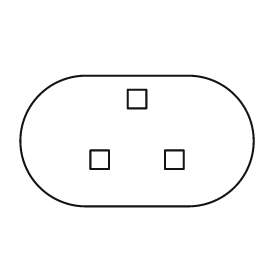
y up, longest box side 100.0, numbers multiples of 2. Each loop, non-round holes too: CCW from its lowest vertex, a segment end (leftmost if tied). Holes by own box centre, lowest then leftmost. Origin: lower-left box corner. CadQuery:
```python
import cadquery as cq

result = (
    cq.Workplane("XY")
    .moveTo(28.0, 0.0)
    .lineTo(72.0, 0.0)
    .threePointArc((100.0, 28.0), (72.0, 56.0))
    .lineTo(28.0, 56.0)
    .threePointArc((0.0, 28.0), (28.0, 0.0))
    .close()
    .moveTo(30.0, 16.0)
    .lineTo(38.0, 16.0)
    .lineTo(38.0, 24.0)
    .lineTo(30.0, 24.0)
    .close()
    .moveTo(62.0, 16.0)
    .lineTo(70.0, 16.0)
    .lineTo(70.0, 24.0)
    .lineTo(62.0, 24.0)
    .close()
    .moveTo(46.0, 42.0)
    .lineTo(54.0, 42.0)
    .lineTo(54.0, 50.0)
    .lineTo(46.0, 50.0)
    .close()
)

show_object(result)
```